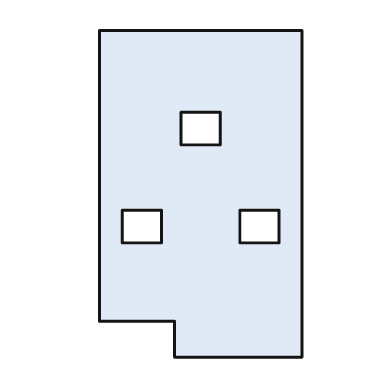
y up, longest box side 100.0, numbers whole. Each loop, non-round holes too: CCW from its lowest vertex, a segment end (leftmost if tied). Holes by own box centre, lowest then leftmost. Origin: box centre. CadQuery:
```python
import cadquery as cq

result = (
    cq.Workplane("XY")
    .moveTo(-8.0, -50.0)
    .lineTo(31.0, -50.0)
    .lineTo(31.0, 50.0)
    .lineTo(-31.0, 50.0)
    .lineTo(-31.0, -39.0)
    .lineTo(-8.0, -39.0)
    .close()
    .moveTo(-24.0, -15.0)
    .lineTo(-12.0, -15.0)
    .lineTo(-12.0, -5.0)
    .lineTo(-24.0, -5.0)
    .close()
    .moveTo(12.0, -15.0)
    .lineTo(24.0, -15.0)
    .lineTo(24.0, -5.0)
    .lineTo(12.0, -5.0)
    .close()
    .moveTo(-6.0, 15.0)
    .lineTo(6.0, 15.0)
    .lineTo(6.0, 25.0)
    .lineTo(-6.0, 25.0)
    .close()
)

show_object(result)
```